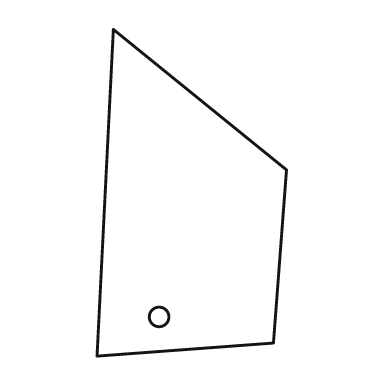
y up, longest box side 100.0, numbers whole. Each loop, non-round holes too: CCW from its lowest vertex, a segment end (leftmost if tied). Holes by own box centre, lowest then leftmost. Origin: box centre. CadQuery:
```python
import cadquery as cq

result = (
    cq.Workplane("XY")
    .moveTo(-29.0, -50.0)
    .lineTo(25.0, -46.0)
    .lineTo(29.0, 7.0)
    .lineTo(-24.0, 50.0)
    .close()
    .moveTo(-10.0, -38.0)
    .circle(3.0)
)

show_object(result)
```